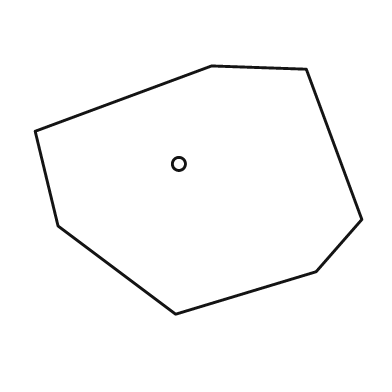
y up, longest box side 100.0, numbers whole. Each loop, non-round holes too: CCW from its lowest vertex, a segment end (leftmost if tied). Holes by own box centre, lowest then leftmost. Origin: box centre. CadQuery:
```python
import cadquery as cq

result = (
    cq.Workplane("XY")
    .moveTo(-7.0, -38.0)
    .lineTo(36.0, -25.0)
    .lineTo(50.0, -9.0)
    .lineTo(33.0, 37.0)
    .lineTo(4.0, 38.0)
    .lineTo(-50.0, 18.0)
    .lineTo(-43.0, -11.0)
    .close()
    .moveTo(-6.0, 8.0)
    .circle(2.0)
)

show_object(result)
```